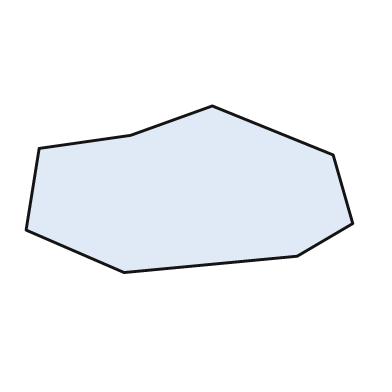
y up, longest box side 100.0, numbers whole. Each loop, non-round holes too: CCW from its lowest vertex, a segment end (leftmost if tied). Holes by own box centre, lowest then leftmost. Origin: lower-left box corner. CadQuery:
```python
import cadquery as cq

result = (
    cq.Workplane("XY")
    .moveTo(30.0, 0.0)
    .lineTo(83.0, 5.0)
    .lineTo(100.0, 15.0)
    .lineTo(94.0, 36.0)
    .lineTo(57.0, 51.0)
    .lineTo(32.0, 42.0)
    .lineTo(4.0, 38.0)
    .lineTo(0.0, 13.0)
    .close()
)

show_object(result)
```